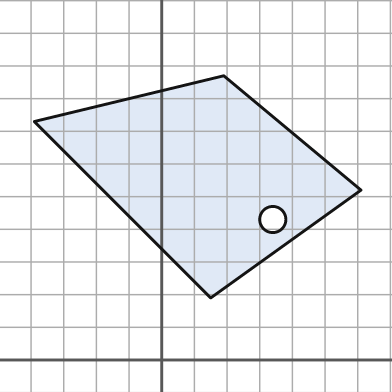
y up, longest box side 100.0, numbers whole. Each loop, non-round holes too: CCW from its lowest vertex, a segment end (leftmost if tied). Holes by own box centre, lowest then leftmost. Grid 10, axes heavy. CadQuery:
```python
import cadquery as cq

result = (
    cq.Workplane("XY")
    .moveTo(15.0, 19.0)
    .lineTo(61.0, 52.0)
    .lineTo(19.0, 87.0)
    .lineTo(-39.0, 73.0)
    .close()
    .moveTo(34.0, 43.0)
    .circle(4.0)
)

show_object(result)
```